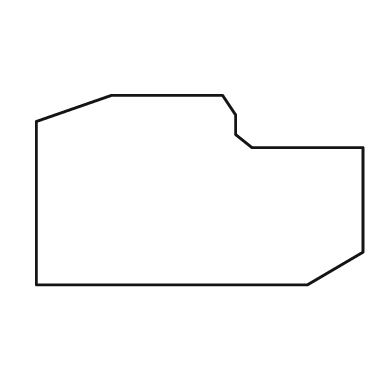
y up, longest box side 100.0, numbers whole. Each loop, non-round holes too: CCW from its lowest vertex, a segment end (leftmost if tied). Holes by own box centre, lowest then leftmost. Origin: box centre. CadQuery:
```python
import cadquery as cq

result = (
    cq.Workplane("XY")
    .moveTo(-50.0, -29.0)
    .lineTo(33.0, -29.0)
    .lineTo(50.0, -19.0)
    .lineTo(50.0, 13.0)
    .lineTo(16.0, 13.0)
    .lineTo(11.0, 17.0)
    .lineTo(11.0, 23.0)
    .lineTo(7.0, 29.0)
    .lineTo(-27.0, 29.0)
    .lineTo(-50.0, 21.0)
    .close()
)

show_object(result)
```